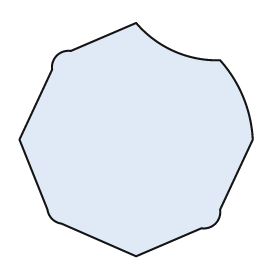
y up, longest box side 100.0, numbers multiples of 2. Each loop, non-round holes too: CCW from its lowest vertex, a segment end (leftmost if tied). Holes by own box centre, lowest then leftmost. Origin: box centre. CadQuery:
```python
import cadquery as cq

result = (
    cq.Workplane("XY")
    .moveTo(0.0, -50.0)
    .lineTo(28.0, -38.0)
    .threePointArc((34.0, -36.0), (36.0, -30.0))
    .lineTo(50.0, 0.0)
    .threePointArc((46.0, 18.0), (36.0, 34.0))
    .threePointArc((16.0, 38.0), (0.0, 50.0))
    .lineTo(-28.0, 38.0)
    .threePointArc((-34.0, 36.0), (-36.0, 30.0))
    .lineTo(-50.0, 0.0)
    .lineTo(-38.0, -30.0)
    .threePointArc((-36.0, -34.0), (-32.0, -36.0))
    .close()
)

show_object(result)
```